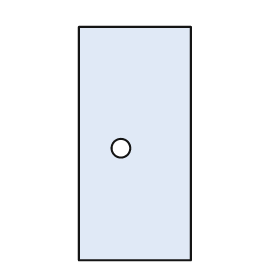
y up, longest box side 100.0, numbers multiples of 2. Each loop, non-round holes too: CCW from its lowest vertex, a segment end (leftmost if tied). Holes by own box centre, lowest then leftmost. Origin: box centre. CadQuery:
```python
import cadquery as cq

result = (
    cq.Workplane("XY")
    .moveTo(-24.0, -50.0)
    .lineTo(24.0, -50.0)
    .lineTo(24.0, 50.0)
    .lineTo(-24.0, 50.0)
    .close()
    .moveTo(-6.0, -2.0)
    .circle(4.0)
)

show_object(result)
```